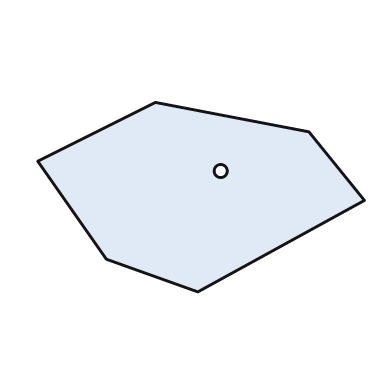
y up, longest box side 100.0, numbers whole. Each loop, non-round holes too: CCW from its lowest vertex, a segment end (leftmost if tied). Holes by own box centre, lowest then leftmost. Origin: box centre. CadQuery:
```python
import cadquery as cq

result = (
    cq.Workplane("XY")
    .moveTo(-1.0, -29.0)
    .lineTo(50.0, -1.0)
    .lineTo(33.0, 20.0)
    .lineTo(-14.0, 29.0)
    .lineTo(-50.0, 11.0)
    .lineTo(-29.0, -19.0)
    .close()
    .moveTo(6.0, 8.0)
    .circle(2.0)
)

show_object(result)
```